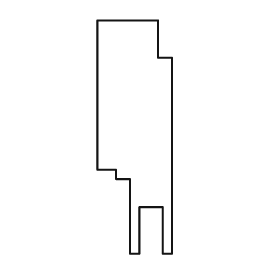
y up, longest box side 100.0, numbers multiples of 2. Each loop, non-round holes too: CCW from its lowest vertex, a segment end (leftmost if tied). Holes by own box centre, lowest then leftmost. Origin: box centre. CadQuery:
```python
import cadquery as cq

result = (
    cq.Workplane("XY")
    .moveTo(-2.0, -50.0)
    .lineTo(2.0, -50.0)
    .lineTo(2.0, -30.0)
    .lineTo(12.0, -30.0)
    .lineTo(12.0, -50.0)
    .lineTo(16.0, -50.0)
    .lineTo(16.0, 34.0)
    .lineTo(10.0, 34.0)
    .lineTo(10.0, 50.0)
    .lineTo(-16.0, 50.0)
    .lineTo(-16.0, -14.0)
    .lineTo(-8.0, -14.0)
    .lineTo(-8.0, -18.0)
    .lineTo(-2.0, -18.0)
    .close()
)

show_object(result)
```